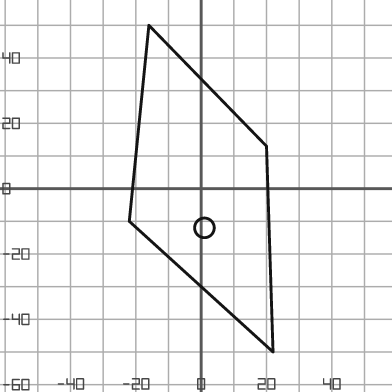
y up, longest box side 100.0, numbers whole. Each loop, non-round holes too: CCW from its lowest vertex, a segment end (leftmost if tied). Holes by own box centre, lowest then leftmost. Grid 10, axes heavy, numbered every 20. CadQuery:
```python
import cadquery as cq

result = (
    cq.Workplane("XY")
    .moveTo(22.0, -50.0)
    .lineTo(20.0, 13.0)
    .lineTo(-16.0, 50.0)
    .lineTo(-22.0, -10.0)
    .close()
    .moveTo(1.0, -12.0)
    .circle(3.0)
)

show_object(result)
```